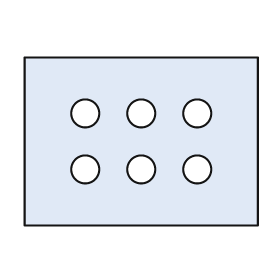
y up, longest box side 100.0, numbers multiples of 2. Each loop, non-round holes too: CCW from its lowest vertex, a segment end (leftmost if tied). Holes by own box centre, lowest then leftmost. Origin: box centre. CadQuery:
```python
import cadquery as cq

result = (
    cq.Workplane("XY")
    .moveTo(-50.0, -36.0)
    .lineTo(50.0, -36.0)
    .lineTo(50.0, 36.0)
    .lineTo(-50.0, 36.0)
    .close()
    .moveTo(-24.0, -12.0)
    .circle(6.0)
    .moveTo(0.0, -12.0)
    .circle(6.0)
    .moveTo(24.0, -12.0)
    .circle(6.0)
    .moveTo(-24.0, 12.0)
    .circle(6.0)
    .moveTo(0.0, 12.0)
    .circle(6.0)
    .moveTo(24.0, 12.0)
    .circle(6.0)
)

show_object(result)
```